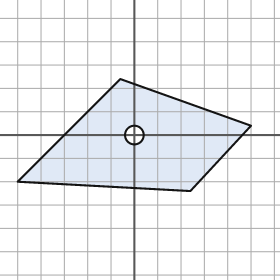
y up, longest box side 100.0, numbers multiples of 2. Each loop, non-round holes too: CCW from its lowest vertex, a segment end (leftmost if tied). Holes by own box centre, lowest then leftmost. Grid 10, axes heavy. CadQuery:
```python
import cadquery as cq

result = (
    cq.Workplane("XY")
    .moveTo(24.0, -24.0)
    .lineTo(50.0, 4.0)
    .lineTo(-6.0, 24.0)
    .lineTo(-50.0, -20.0)
    .close()
    .moveTo(0.0, 0.0)
    .circle(4.0)
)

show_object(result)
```